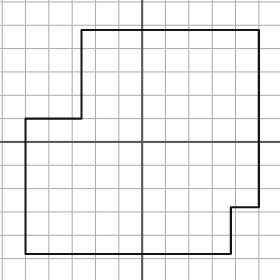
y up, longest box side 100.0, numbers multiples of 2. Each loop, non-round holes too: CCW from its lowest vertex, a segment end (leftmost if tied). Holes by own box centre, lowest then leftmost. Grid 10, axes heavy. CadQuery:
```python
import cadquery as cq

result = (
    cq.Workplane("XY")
    .moveTo(-50.0, -48.0)
    .lineTo(38.0, -48.0)
    .lineTo(38.0, -28.0)
    .lineTo(50.0, -28.0)
    .lineTo(50.0, 48.0)
    .lineTo(-26.0, 48.0)
    .lineTo(-26.0, 10.0)
    .lineTo(-50.0, 10.0)
    .close()
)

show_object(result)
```